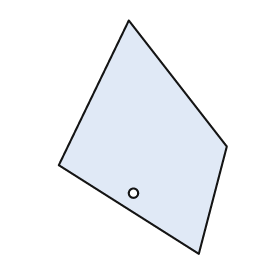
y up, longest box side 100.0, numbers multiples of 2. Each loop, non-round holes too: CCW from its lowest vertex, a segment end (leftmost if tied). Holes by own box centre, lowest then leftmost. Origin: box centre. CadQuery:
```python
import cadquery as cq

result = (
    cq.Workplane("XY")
    .moveTo(24.0, -50.0)
    .lineTo(36.0, -4.0)
    .lineTo(-6.0, 50.0)
    .lineTo(-36.0, -12.0)
    .close()
    .moveTo(-4.0, -24.0)
    .circle(2.0)
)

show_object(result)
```